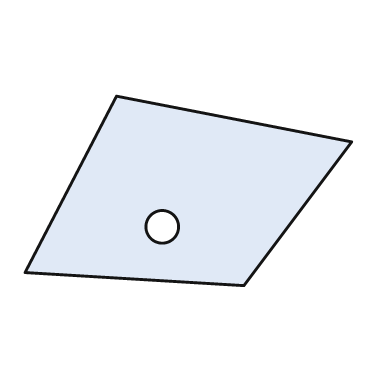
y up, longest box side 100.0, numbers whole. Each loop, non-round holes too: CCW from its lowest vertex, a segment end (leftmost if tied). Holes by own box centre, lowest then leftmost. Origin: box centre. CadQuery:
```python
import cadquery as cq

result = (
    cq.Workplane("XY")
    .moveTo(17.0, -29.0)
    .lineTo(50.0, 15.0)
    .lineTo(-22.0, 29.0)
    .lineTo(-50.0, -25.0)
    .close()
    .moveTo(-8.0, -11.0)
    .circle(5.0)
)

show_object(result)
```